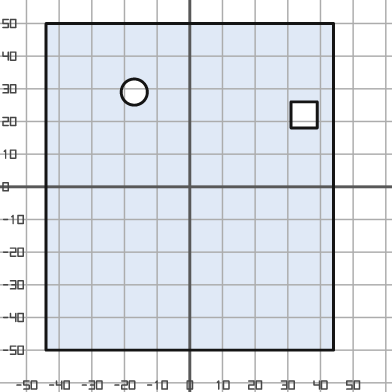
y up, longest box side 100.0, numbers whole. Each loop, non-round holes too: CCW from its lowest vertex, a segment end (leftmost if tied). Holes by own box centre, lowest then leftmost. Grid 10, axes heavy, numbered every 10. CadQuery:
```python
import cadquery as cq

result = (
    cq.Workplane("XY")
    .moveTo(-44.0, -50.0)
    .lineTo(44.0, -50.0)
    .lineTo(44.0, 50.0)
    .lineTo(-44.0, 50.0)
    .close()
    .moveTo(31.0, 18.0)
    .lineTo(39.0, 18.0)
    .lineTo(39.0, 26.0)
    .lineTo(31.0, 26.0)
    .close()
    .moveTo(-17.0, 29.0)
    .circle(4.0)
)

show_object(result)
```